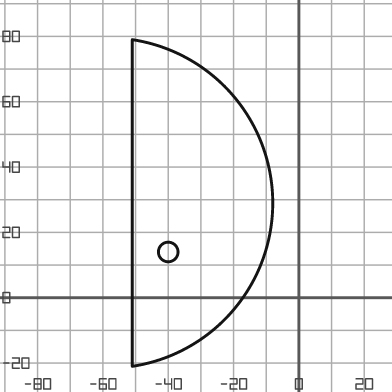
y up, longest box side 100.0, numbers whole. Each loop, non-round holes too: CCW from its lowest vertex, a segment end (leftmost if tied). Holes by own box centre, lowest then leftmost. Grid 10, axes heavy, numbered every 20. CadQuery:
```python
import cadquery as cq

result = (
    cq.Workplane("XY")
    .moveTo(-51.0, -21.0)
    .threePointArc((-8.0, 29.0), (-51.0, 79.0))
    .close()
    .moveTo(-40.0, 14.0)
    .circle(3.0)
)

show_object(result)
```